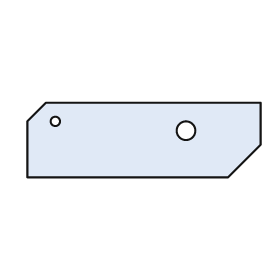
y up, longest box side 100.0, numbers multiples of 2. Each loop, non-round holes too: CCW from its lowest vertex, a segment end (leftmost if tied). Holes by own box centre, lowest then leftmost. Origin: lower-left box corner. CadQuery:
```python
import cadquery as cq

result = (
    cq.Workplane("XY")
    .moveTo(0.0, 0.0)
    .lineTo(86.0, 0.0)
    .lineTo(100.0, 14.0)
    .lineTo(100.0, 32.0)
    .lineTo(8.0, 32.0)
    .lineTo(0.0, 24.0)
    .close()
    .moveTo(68.0, 20.0)
    .circle(4.0)
    .moveTo(12.0, 24.0)
    .circle(2.0)
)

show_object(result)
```